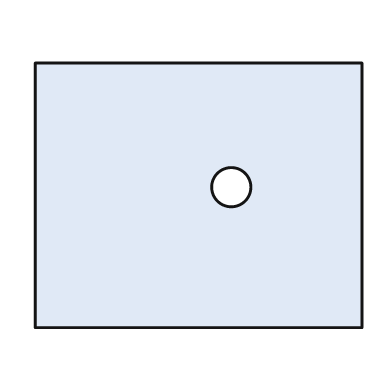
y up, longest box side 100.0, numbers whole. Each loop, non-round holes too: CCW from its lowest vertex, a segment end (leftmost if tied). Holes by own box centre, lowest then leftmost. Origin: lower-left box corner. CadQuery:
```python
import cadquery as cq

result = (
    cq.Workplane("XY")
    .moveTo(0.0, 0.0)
    .lineTo(100.0, 0.0)
    .lineTo(100.0, 81.0)
    .lineTo(0.0, 81.0)
    .close()
    .moveTo(60.0, 43.0)
    .circle(6.0)
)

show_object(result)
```